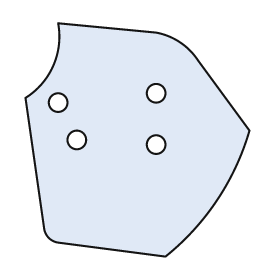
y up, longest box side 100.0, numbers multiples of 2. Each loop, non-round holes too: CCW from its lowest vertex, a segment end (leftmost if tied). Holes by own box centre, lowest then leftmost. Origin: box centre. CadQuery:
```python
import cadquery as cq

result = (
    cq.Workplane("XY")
    .moveTo(12.0, -50.0)
    .threePointArc((34.0, -26.0), (48.0, 4.0))
    .lineTo(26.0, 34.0)
    .threePointArc((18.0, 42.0), (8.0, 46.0))
    .lineTo(-34.0, 50.0)
    .threePointArc((-36.0, 32.0), (-48.0, 18.0))
    .lineTo(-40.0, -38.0)
    .threePointArc((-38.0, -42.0), (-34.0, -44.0))
    .close()
    .moveTo(8.0, -2.0)
    .circle(4.0)
    .moveTo(-26.0, 0.0)
    .circle(4.0)
    .moveTo(-34.0, 16.0)
    .circle(4.0)
    .moveTo(8.0, 20.0)
    .circle(4.0)
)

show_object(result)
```